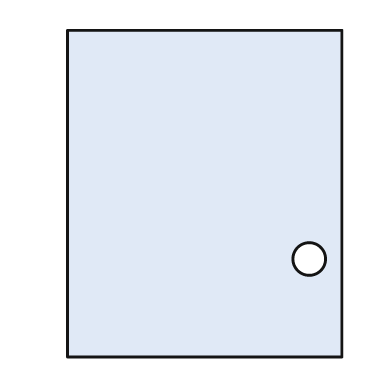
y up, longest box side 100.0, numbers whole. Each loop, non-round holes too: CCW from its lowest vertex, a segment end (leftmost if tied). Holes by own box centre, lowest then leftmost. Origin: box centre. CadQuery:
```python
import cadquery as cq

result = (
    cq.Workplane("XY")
    .moveTo(-42.0, -50.0)
    .lineTo(42.0, -50.0)
    .lineTo(42.0, 50.0)
    .lineTo(-42.0, 50.0)
    .close()
    .moveTo(32.0, -20.0)
    .circle(5.0)
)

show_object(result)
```